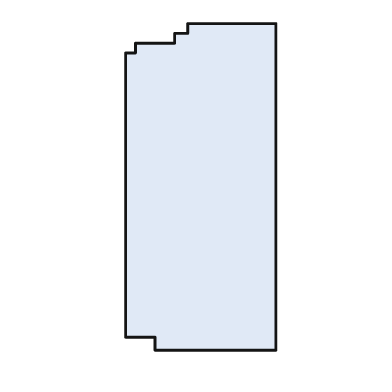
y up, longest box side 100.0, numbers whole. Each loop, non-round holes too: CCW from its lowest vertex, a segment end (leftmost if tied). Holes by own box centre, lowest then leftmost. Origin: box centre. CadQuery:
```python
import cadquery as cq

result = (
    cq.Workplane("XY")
    .moveTo(-14.0, -50.0)
    .lineTo(23.0, -50.0)
    .lineTo(23.0, 50.0)
    .lineTo(-4.0, 50.0)
    .lineTo(-4.0, 47.0)
    .lineTo(-8.0, 47.0)
    .lineTo(-8.0, 44.0)
    .lineTo(-20.0, 44.0)
    .lineTo(-20.0, 41.0)
    .lineTo(-23.0, 41.0)
    .lineTo(-23.0, -46.0)
    .lineTo(-14.0, -46.0)
    .close()
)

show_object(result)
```